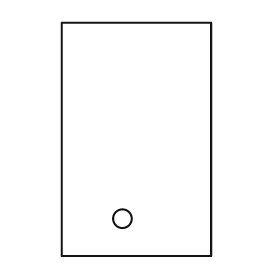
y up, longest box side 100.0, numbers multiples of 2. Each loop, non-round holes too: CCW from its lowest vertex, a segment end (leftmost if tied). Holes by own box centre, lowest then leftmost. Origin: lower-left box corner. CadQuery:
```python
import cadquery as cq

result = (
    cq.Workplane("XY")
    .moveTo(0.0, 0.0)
    .lineTo(64.0, 0.0)
    .lineTo(64.0, 100.0)
    .lineTo(0.0, 100.0)
    .close()
    .moveTo(26.0, 16.0)
    .circle(4.0)
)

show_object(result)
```